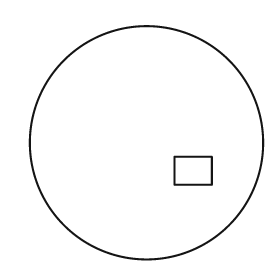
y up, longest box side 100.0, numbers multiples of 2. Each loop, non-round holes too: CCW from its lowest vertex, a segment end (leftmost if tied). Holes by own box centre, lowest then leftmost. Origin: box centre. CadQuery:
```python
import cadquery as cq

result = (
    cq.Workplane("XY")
    .moveTo(0.0, 0.0)
    .circle(50.0)
    .moveTo(12.0, -18.0)
    .lineTo(28.0, -18.0)
    .lineTo(28.0, -6.0)
    .lineTo(12.0, -6.0)
    .close()
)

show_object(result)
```